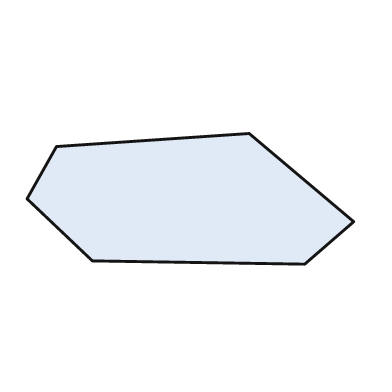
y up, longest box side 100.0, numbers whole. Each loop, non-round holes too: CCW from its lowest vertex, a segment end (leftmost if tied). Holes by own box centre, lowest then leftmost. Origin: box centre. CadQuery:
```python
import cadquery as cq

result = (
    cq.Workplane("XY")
    .moveTo(35.0, -20.0)
    .lineTo(50.0, -7.0)
    .lineTo(18.0, 20.0)
    .lineTo(-41.0, 16.0)
    .lineTo(-50.0, 0.0)
    .lineTo(-30.0, -19.0)
    .close()
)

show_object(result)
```